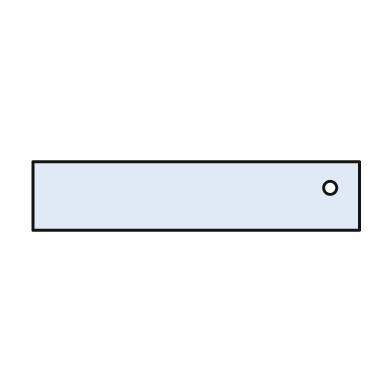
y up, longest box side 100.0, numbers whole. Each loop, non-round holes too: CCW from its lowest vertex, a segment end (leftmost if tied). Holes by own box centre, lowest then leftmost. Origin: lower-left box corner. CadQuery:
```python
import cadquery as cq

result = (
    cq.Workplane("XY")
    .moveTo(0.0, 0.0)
    .lineTo(100.0, 0.0)
    .lineTo(100.0, 21.0)
    .lineTo(0.0, 21.0)
    .close()
    .moveTo(91.0, 13.0)
    .circle(2.0)
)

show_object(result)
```